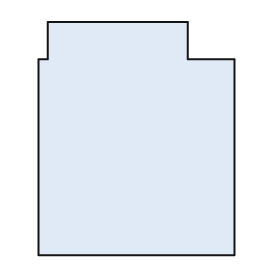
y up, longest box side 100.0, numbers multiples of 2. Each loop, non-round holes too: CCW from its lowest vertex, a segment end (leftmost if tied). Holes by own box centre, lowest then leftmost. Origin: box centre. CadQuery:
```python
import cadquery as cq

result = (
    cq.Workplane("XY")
    .moveTo(-42.0, -50.0)
    .lineTo(42.0, -50.0)
    .lineTo(42.0, 34.0)
    .lineTo(22.0, 34.0)
    .lineTo(22.0, 50.0)
    .lineTo(-38.0, 50.0)
    .lineTo(-38.0, 34.0)
    .lineTo(-42.0, 34.0)
    .close()
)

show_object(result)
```